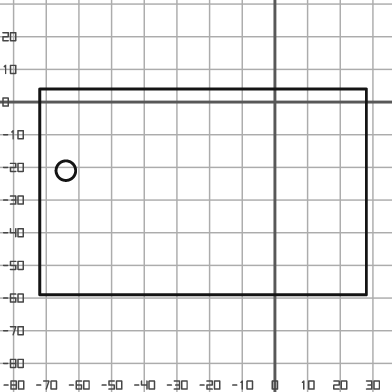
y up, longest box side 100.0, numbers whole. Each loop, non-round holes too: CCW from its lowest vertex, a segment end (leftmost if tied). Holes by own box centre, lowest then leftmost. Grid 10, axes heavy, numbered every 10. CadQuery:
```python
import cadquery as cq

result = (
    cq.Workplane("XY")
    .moveTo(-72.0, -59.0)
    .lineTo(28.0, -59.0)
    .lineTo(28.0, 4.0)
    .lineTo(-72.0, 4.0)
    .close()
    .moveTo(-64.0, -21.0)
    .circle(3.0)
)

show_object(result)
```